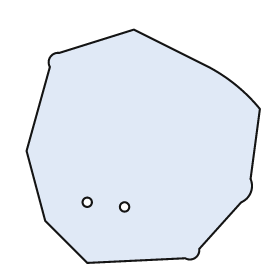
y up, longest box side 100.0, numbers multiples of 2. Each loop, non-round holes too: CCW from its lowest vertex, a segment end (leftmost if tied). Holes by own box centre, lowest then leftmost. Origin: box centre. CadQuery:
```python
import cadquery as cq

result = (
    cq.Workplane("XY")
    .moveTo(-24.0, -50.0)
    .lineTo(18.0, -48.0)
    .threePointArc((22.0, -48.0), (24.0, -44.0))
    .lineTo(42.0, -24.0)
    .threePointArc((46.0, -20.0), (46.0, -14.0))
    .lineTo(50.0, 16.0)
    .threePointArc((40.0, 26.0), (28.0, 34.0))
    .lineTo(-4.0, 50.0)
    .lineTo(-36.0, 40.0)
    .threePointArc((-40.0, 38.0), (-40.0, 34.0))
    .lineTo(-50.0, -2.0)
    .lineTo(-42.0, -32.0)
    .close()
    .moveTo(-8.0, -26.0)
    .circle(2.0)
    .moveTo(-24.0, -24.0)
    .circle(2.0)
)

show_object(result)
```